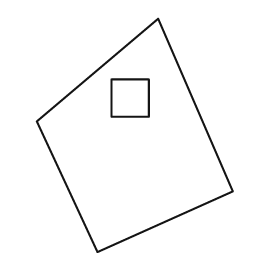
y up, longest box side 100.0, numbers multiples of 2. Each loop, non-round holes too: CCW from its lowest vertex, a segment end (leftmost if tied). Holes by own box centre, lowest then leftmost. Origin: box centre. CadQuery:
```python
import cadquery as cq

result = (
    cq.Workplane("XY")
    .moveTo(-16.0, -50.0)
    .lineTo(42.0, -24.0)
    .lineTo(10.0, 50.0)
    .lineTo(-42.0, 6.0)
    .close()
    .moveTo(-10.0, 8.0)
    .lineTo(6.0, 8.0)
    .lineTo(6.0, 24.0)
    .lineTo(-10.0, 24.0)
    .close()
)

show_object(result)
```